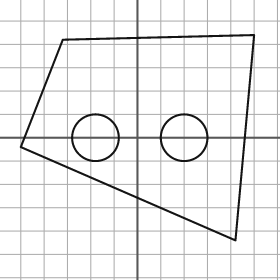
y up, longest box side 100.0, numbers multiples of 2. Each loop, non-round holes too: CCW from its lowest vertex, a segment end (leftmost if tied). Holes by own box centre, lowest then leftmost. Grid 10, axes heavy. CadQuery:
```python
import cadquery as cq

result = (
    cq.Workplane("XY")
    .moveTo(42.0, -44.0)
    .lineTo(50.0, 44.0)
    .lineTo(-32.0, 42.0)
    .lineTo(-50.0, -4.0)
    .close()
    .moveTo(-18.0, 0.0)
    .circle(10.0)
    .moveTo(20.0, 0.0)
    .circle(10.0)
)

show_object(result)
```